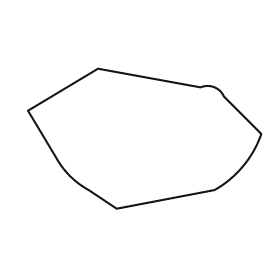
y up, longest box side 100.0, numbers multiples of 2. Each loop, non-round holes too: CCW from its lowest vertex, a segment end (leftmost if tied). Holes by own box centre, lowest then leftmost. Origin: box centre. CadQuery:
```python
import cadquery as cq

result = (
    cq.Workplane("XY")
    .moveTo(-12.0, -30.0)
    .lineTo(30.0, -22.0)
    .threePointArc((42.0, -12.0), (50.0, 2.0))
    .lineTo(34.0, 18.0)
    .threePointArc((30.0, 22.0), (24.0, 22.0))
    .lineTo(-20.0, 30.0)
    .lineTo(-50.0, 12.0)
    .lineTo(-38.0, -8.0)
    .threePointArc((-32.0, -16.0), (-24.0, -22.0))
    .close()
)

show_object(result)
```